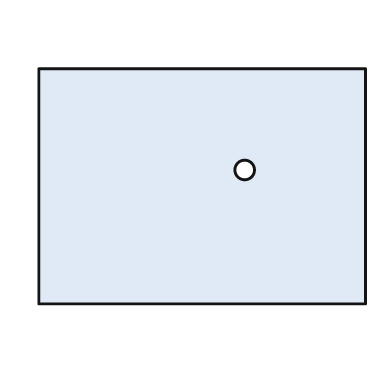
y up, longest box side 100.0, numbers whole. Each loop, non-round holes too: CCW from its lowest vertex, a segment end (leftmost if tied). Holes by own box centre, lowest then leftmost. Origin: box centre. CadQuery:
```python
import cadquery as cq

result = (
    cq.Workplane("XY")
    .moveTo(-50.0, -36.0)
    .lineTo(50.0, -36.0)
    .lineTo(50.0, 36.0)
    .lineTo(-50.0, 36.0)
    .close()
    .moveTo(13.0, 5.0)
    .circle(3.0)
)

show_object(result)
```